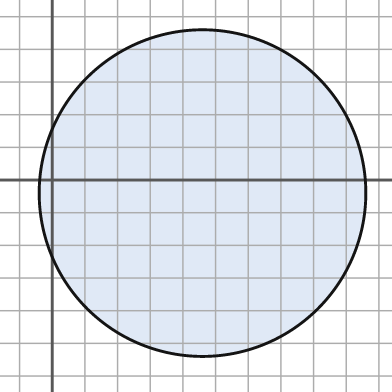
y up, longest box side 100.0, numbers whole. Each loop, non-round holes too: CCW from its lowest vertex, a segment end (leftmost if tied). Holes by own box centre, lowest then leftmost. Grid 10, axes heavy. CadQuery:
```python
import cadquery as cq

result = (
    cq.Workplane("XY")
    .moveTo(46.0, -4.0)
    .circle(50.0)
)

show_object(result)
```